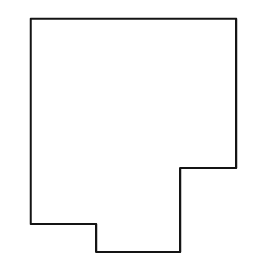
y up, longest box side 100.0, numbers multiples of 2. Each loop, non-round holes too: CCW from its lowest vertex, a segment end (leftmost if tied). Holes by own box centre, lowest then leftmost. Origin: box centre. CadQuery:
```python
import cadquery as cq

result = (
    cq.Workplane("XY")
    .moveTo(-16.0, -50.0)
    .lineTo(20.0, -50.0)
    .lineTo(20.0, -14.0)
    .lineTo(44.0, -14.0)
    .lineTo(44.0, 50.0)
    .lineTo(-44.0, 50.0)
    .lineTo(-44.0, -38.0)
    .lineTo(-16.0, -38.0)
    .close()
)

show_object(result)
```